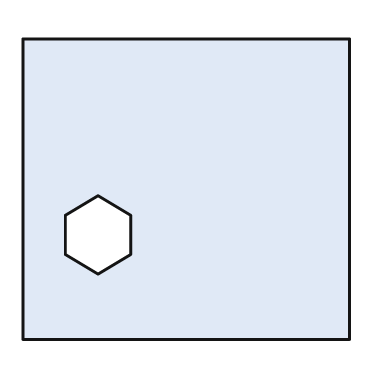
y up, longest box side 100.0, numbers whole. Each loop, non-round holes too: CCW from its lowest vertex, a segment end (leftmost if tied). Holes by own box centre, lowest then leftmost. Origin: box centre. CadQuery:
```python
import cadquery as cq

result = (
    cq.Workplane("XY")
    .moveTo(-50.0, -46.0)
    .lineTo(50.0, -46.0)
    .lineTo(50.0, 46.0)
    .lineTo(-50.0, 46.0)
    .close()
    .moveTo(-27.0, -26.0)
    .lineTo(-17.0, -20.0)
    .lineTo(-17.0, -8.0)
    .lineTo(-27.0, -2.0)
    .lineTo(-37.0, -8.0)
    .lineTo(-37.0, -20.0)
    .close()
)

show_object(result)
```